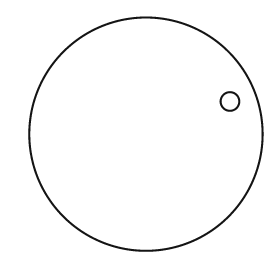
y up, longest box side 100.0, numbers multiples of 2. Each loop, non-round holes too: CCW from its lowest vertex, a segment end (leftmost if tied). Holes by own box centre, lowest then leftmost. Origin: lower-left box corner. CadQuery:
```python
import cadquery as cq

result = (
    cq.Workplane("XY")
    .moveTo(50.0, 50.0)
    .circle(50.0)
    .moveTo(86.0, 64.0)
    .circle(4.0)
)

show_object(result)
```